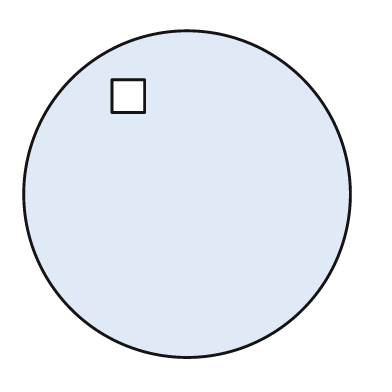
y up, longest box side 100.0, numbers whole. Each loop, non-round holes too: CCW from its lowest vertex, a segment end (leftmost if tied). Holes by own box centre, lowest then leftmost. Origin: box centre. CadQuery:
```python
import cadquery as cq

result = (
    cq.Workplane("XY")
    .moveTo(0.0, 0.0)
    .circle(50.0)
    .moveTo(-23.0, 25.0)
    .lineTo(-13.0, 25.0)
    .lineTo(-13.0, 35.0)
    .lineTo(-23.0, 35.0)
    .close()
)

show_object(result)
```